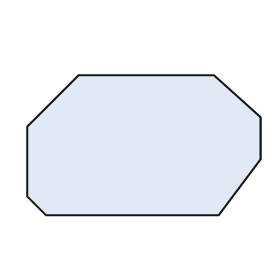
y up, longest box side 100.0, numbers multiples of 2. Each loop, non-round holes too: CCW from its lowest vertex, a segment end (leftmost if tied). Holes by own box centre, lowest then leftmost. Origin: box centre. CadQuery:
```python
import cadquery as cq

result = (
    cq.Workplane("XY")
    .moveTo(-42.0, -30.0)
    .lineTo(32.0, -30.0)
    .lineTo(50.0, -6.0)
    .lineTo(50.0, 12.0)
    .lineTo(30.0, 30.0)
    .lineTo(-28.0, 30.0)
    .lineTo(-50.0, 8.0)
    .lineTo(-50.0, -22.0)
    .close()
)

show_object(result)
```